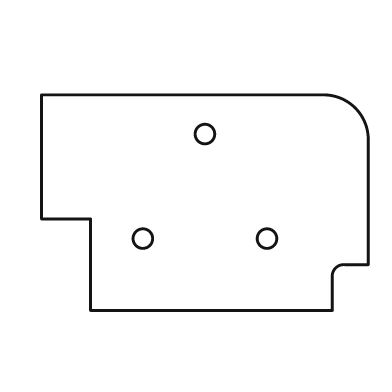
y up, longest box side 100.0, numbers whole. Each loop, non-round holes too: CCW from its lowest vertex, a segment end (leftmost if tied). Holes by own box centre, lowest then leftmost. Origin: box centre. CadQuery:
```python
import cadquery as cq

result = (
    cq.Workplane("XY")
    .moveTo(-35.0, -33.0)
    .lineTo(39.0, -33.0)
    .lineTo(39.0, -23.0)
    .threePointArc((40.0, -20.0), (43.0, -19.0))
    .lineTo(50.0, -19.0)
    .lineTo(50.0, 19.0)
    .threePointArc((46.0, 29.0), (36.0, 33.0))
    .lineTo(-50.0, 33.0)
    .lineTo(-50.0, -5.0)
    .lineTo(-35.0, -5.0)
    .close()
    .moveTo(-19.0, -11.0)
    .circle(3.0)
    .moveTo(19.0, -11.0)
    .circle(3.0)
    .moveTo(0.0, 21.0)
    .circle(3.0)
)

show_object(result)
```